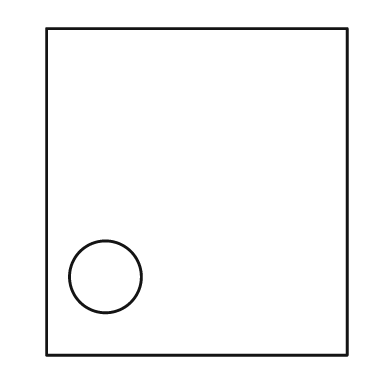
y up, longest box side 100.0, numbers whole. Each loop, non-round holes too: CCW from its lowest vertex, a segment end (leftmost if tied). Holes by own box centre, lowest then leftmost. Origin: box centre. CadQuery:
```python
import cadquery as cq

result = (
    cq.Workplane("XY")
    .moveTo(-46.0, -50.0)
    .lineTo(46.0, -50.0)
    .lineTo(46.0, 50.0)
    .lineTo(-46.0, 50.0)
    .close()
    .moveTo(-28.0, -26.0)
    .circle(11.0)
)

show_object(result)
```